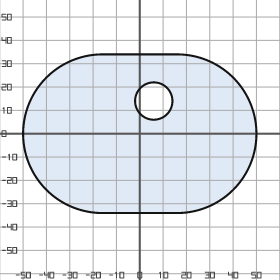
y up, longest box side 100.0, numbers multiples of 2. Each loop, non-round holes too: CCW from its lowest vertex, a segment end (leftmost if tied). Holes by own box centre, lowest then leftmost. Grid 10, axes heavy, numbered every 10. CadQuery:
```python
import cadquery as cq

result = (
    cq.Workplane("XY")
    .moveTo(-16.0, -34.0)
    .lineTo(16.0, -34.0)
    .threePointArc((50.0, 0.0), (16.0, 34.0))
    .lineTo(-16.0, 34.0)
    .threePointArc((-50.0, 0.0), (-16.0, -34.0))
    .close()
    .moveTo(6.0, 14.0)
    .circle(8.0)
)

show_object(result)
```